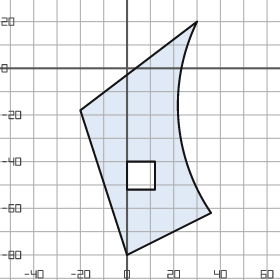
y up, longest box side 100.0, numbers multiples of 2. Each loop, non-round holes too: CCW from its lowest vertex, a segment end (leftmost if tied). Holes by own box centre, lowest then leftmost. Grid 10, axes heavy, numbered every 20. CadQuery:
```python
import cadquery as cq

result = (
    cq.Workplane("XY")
    .moveTo(0.0, -80.0)
    .lineTo(36.0, -62.0)
    .threePointArc((22.0, -22.0), (30.0, 20.0))
    .lineTo(-20.0, -18.0)
    .close()
    .moveTo(0.0, -52.0)
    .lineTo(12.0, -52.0)
    .lineTo(12.0, -40.0)
    .lineTo(0.0, -40.0)
    .close()
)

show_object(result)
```